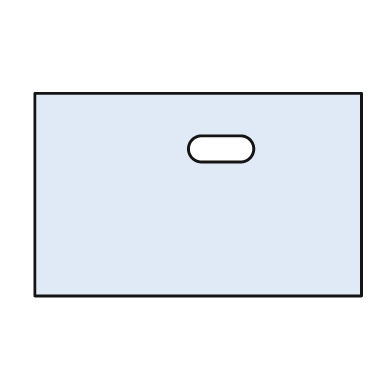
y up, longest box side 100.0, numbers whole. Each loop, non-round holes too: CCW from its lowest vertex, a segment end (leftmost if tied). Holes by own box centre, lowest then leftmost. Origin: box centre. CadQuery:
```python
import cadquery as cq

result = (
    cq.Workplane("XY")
    .moveTo(-50.0, -31.0)
    .lineTo(50.0, -31.0)
    .lineTo(50.0, 31.0)
    .lineTo(-50.0, 31.0)
    .close()
    .moveTo(1.0, 10.0)
    .lineTo(13.0, 10.0)
    .threePointArc((17.0, 14.0), (13.0, 18.0))
    .lineTo(1.0, 18.0)
    .threePointArc((-3.0, 14.0), (1.0, 10.0))
    .close()
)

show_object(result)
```